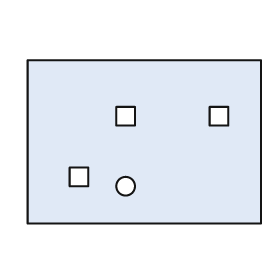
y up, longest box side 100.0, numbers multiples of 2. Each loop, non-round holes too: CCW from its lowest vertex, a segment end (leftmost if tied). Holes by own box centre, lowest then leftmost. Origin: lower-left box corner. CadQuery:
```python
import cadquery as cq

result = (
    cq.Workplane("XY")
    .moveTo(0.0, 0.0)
    .lineTo(100.0, 0.0)
    .lineTo(100.0, 70.0)
    .lineTo(0.0, 70.0)
    .close()
    .moveTo(42.0, 16.0)
    .circle(4.0)
    .moveTo(18.0, 16.0)
    .lineTo(26.0, 16.0)
    .lineTo(26.0, 24.0)
    .lineTo(18.0, 24.0)
    .close()
    .moveTo(38.0, 42.0)
    .lineTo(46.0, 42.0)
    .lineTo(46.0, 50.0)
    .lineTo(38.0, 50.0)
    .close()
    .moveTo(78.0, 42.0)
    .lineTo(86.0, 42.0)
    .lineTo(86.0, 50.0)
    .lineTo(78.0, 50.0)
    .close()
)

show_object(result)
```